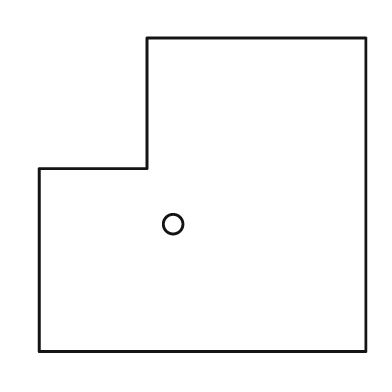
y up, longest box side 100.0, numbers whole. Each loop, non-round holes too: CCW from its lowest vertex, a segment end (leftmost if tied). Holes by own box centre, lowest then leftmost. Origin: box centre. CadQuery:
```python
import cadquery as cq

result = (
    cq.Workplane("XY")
    .moveTo(-50.0, -48.0)
    .lineTo(50.0, -48.0)
    .lineTo(50.0, 48.0)
    .lineTo(-17.0, 48.0)
    .lineTo(-17.0, 8.0)
    .lineTo(-50.0, 8.0)
    .close()
    .moveTo(-9.0, -9.0)
    .circle(3.0)
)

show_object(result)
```